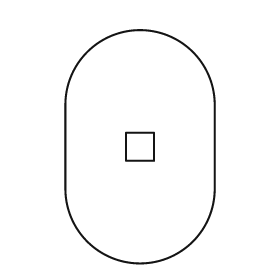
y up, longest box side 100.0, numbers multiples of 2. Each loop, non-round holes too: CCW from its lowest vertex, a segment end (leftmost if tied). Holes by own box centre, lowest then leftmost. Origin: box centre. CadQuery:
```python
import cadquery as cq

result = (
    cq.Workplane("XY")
    .moveTo(-32.0, -18.0)
    .threePointArc((0.0, -50.0), (32.0, -18.0))
    .lineTo(32.0, 18.0)
    .threePointArc((0.0, 50.0), (-32.0, 18.0))
    .close()
    .moveTo(-6.0, -6.0)
    .lineTo(6.0, -6.0)
    .lineTo(6.0, 6.0)
    .lineTo(-6.0, 6.0)
    .close()
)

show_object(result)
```